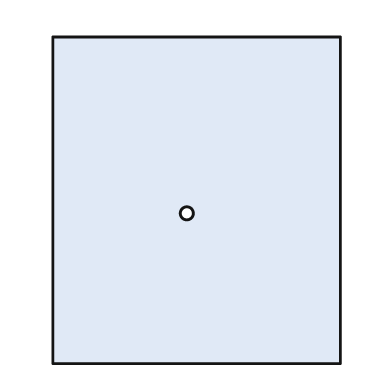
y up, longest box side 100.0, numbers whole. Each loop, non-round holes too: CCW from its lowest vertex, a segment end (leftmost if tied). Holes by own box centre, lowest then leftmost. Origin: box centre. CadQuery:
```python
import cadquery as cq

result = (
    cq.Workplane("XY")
    .moveTo(-44.0, -50.0)
    .lineTo(44.0, -50.0)
    .lineTo(44.0, 50.0)
    .lineTo(-44.0, 50.0)
    .close()
    .moveTo(-3.0, -4.0)
    .circle(2.0)
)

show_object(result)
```